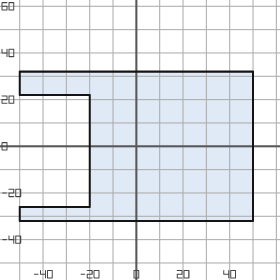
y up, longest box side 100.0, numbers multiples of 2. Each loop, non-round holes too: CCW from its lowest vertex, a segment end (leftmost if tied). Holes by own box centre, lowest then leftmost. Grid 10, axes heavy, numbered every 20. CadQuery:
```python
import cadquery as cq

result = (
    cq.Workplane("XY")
    .moveTo(-50.0, -32.0)
    .lineTo(50.0, -32.0)
    .lineTo(50.0, 32.0)
    .lineTo(-50.0, 32.0)
    .lineTo(-50.0, 22.0)
    .lineTo(-20.0, 22.0)
    .lineTo(-20.0, -26.0)
    .lineTo(-50.0, -26.0)
    .close()
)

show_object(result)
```